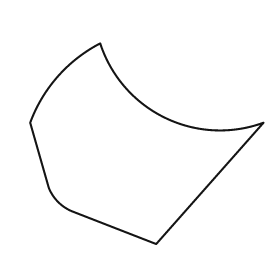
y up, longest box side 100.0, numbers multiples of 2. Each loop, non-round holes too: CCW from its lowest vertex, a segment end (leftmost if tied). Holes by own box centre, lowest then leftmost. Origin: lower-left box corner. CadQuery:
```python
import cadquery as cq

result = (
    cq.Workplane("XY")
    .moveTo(54.0, 0.0)
    .lineTo(100.0, 52.0)
    .threePointArc((58.0, 54.0), (30.0, 86.0))
    .threePointArc((12.0, 72.0), (0.0, 52.0))
    .lineTo(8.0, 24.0)
    .threePointArc((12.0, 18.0), (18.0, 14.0))
    .close()
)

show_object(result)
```